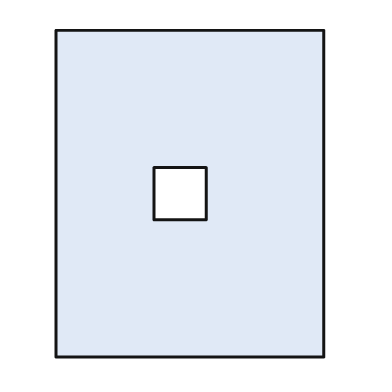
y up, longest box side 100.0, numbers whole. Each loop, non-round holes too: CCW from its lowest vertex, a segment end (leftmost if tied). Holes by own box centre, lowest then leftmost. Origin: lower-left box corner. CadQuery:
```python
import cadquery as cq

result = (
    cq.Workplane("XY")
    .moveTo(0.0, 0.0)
    .lineTo(82.0, 0.0)
    .lineTo(82.0, 100.0)
    .lineTo(0.0, 100.0)
    .close()
    .moveTo(30.0, 42.0)
    .lineTo(46.0, 42.0)
    .lineTo(46.0, 58.0)
    .lineTo(30.0, 58.0)
    .close()
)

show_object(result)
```